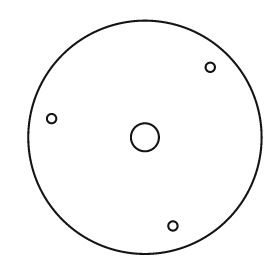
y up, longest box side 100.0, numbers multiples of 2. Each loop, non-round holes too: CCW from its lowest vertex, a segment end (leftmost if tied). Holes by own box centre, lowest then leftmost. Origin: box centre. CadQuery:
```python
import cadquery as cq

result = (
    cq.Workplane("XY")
    .moveTo(0.0, 0.0)
    .circle(50.0)
    .moveTo(12.0, -38.0)
    .circle(2.0)
    .moveTo(0.0, 0.0)
    .circle(6.0)
    .moveTo(-40.0, 8.0)
    .circle(2.0)
    .moveTo(28.0, 30.0)
    .circle(2.0)
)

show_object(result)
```